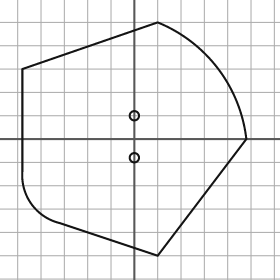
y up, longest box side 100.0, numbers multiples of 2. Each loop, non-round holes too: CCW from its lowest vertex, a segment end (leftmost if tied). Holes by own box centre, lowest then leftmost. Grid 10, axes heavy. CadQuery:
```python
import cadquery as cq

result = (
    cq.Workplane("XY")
    .moveTo(10.0, -50.0)
    .lineTo(48.0, 0.0)
    .threePointArc((36.0, 30.0), (10.0, 50.0))
    .lineTo(-48.0, 30.0)
    .lineTo(-48.0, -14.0)
    .threePointArc((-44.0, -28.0), (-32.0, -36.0))
    .close()
    .moveTo(0.0, -8.0)
    .circle(2.0)
    .moveTo(0.0, 10.0)
    .circle(2.0)
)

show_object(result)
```